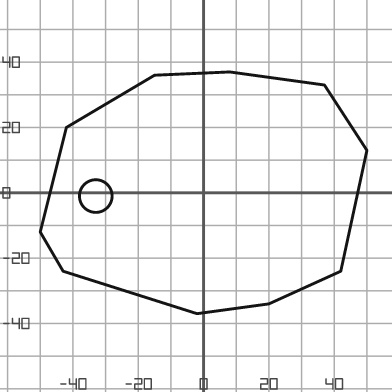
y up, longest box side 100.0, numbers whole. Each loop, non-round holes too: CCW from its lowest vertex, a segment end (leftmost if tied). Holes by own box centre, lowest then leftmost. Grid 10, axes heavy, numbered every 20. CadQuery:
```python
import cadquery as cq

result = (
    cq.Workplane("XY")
    .moveTo(-2.0, -37.0)
    .lineTo(20.0, -34.0)
    .lineTo(42.0, -24.0)
    .lineTo(50.0, 13.0)
    .lineTo(37.0, 33.0)
    .lineTo(8.0, 37.0)
    .lineTo(-15.0, 36.0)
    .lineTo(-42.0, 20.0)
    .lineTo(-50.0, -12.0)
    .lineTo(-43.0, -24.0)
    .close()
    .moveTo(-33.0, -1.0)
    .circle(5.0)
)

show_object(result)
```